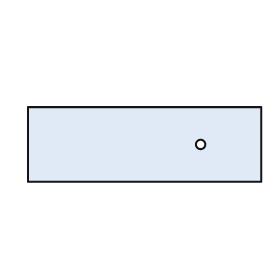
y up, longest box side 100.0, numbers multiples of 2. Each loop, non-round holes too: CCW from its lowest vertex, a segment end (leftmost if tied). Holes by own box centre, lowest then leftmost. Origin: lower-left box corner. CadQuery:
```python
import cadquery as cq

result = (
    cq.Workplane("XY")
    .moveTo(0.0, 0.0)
    .lineTo(100.0, 0.0)
    .lineTo(100.0, 32.0)
    .lineTo(0.0, 32.0)
    .close()
    .moveTo(74.0, 16.0)
    .circle(2.0)
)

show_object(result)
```